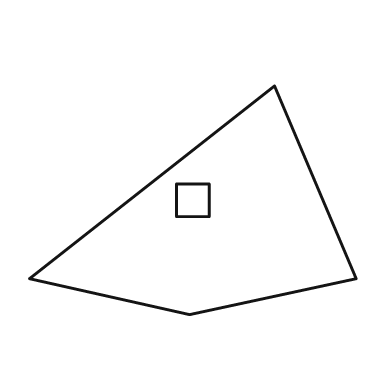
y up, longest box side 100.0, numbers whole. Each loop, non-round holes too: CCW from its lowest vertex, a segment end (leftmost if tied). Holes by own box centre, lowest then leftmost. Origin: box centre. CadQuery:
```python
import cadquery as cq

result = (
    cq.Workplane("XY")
    .moveTo(-1.0, -35.0)
    .lineTo(50.0, -24.0)
    .lineTo(25.0, 35.0)
    .lineTo(-50.0, -24.0)
    .close()
    .moveTo(-5.0, -5.0)
    .lineTo(5.0, -5.0)
    .lineTo(5.0, 5.0)
    .lineTo(-5.0, 5.0)
    .close()
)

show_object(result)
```